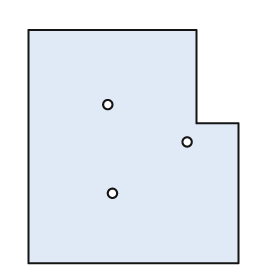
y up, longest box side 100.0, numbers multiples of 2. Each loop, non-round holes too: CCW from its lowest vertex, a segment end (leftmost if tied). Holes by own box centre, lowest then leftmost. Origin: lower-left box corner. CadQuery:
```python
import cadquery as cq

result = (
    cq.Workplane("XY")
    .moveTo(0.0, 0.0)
    .lineTo(90.0, 0.0)
    .lineTo(90.0, 60.0)
    .lineTo(72.0, 60.0)
    .lineTo(72.0, 100.0)
    .lineTo(0.0, 100.0)
    .close()
    .moveTo(36.0, 30.0)
    .circle(2.0)
    .moveTo(68.0, 52.0)
    .circle(2.0)
    .moveTo(34.0, 68.0)
    .circle(2.0)
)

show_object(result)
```